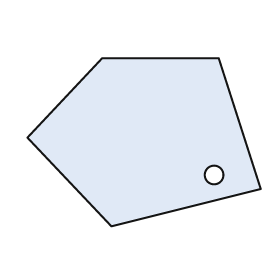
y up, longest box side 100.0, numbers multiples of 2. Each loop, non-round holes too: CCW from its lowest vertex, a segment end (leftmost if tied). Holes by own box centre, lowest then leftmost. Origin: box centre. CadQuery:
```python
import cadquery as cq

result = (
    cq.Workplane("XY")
    .moveTo(-14.0, -36.0)
    .lineTo(50.0, -20.0)
    .lineTo(32.0, 36.0)
    .lineTo(-18.0, 36.0)
    .lineTo(-50.0, 2.0)
    .close()
    .moveTo(30.0, -14.0)
    .circle(4.0)
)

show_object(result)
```